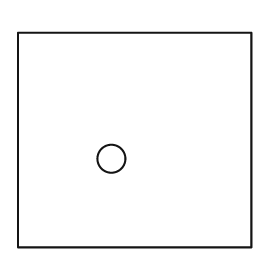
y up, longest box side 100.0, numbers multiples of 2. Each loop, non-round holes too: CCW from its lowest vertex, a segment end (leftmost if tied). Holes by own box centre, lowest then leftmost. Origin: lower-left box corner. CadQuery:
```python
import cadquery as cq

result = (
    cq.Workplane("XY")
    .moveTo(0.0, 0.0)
    .lineTo(100.0, 0.0)
    .lineTo(100.0, 92.0)
    .lineTo(0.0, 92.0)
    .close()
    .moveTo(40.0, 38.0)
    .circle(6.0)
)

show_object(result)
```